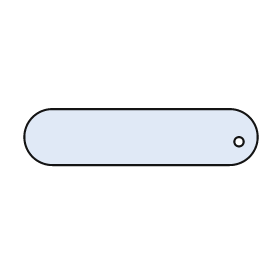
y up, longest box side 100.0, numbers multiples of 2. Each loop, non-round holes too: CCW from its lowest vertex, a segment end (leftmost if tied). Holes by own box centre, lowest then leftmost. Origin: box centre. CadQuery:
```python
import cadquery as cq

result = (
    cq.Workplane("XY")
    .moveTo(-38.0, -12.0)
    .lineTo(38.0, -12.0)
    .threePointArc((50.0, 0.0), (38.0, 12.0))
    .lineTo(-38.0, 12.0)
    .threePointArc((-50.0, 0.0), (-38.0, -12.0))
    .close()
    .moveTo(42.0, -2.0)
    .circle(2.0)
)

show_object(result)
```